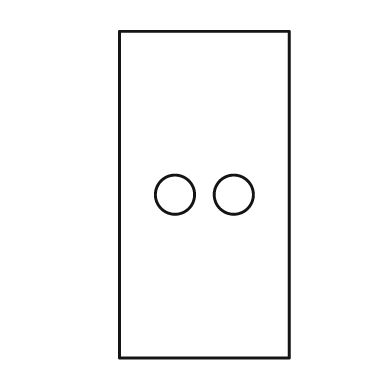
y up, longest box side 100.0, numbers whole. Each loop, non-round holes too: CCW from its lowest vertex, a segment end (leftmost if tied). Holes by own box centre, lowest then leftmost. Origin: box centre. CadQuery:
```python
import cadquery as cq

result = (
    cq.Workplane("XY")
    .moveTo(-26.0, -50.0)
    .lineTo(26.0, -50.0)
    .lineTo(26.0, 50.0)
    .lineTo(-26.0, 50.0)
    .close()
    .moveTo(-9.0, 0.0)
    .circle(6.0)
    .moveTo(9.0, 0.0)
    .circle(6.0)
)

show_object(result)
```